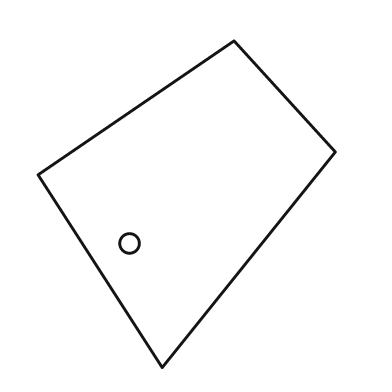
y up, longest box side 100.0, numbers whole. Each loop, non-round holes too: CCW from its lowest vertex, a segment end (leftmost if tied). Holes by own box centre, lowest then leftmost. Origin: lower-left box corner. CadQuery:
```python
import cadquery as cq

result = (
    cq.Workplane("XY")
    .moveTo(38.0, 0.0)
    .lineTo(91.0, 66.0)
    .lineTo(60.0, 100.0)
    .lineTo(0.0, 59.0)
    .close()
    .moveTo(28.0, 38.0)
    .circle(3.0)
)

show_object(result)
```